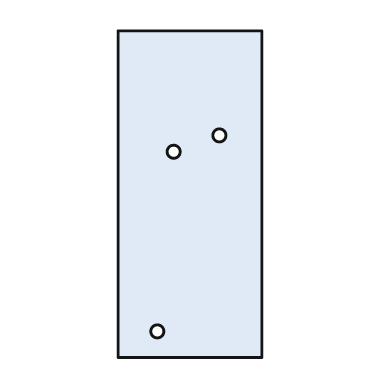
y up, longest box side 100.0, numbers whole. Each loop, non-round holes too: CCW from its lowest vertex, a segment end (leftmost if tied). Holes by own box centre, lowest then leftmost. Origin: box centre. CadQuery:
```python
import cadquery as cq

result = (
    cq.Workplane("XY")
    .moveTo(-22.0, -50.0)
    .lineTo(22.0, -50.0)
    .lineTo(22.0, 50.0)
    .lineTo(-22.0, 50.0)
    .close()
    .moveTo(-10.0, -42.0)
    .circle(2.0)
    .moveTo(-5.0, 13.0)
    .circle(2.0)
    .moveTo(9.0, 18.0)
    .circle(2.0)
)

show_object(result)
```